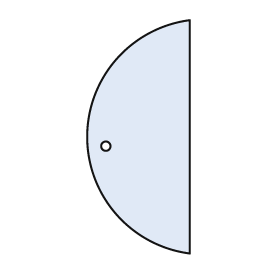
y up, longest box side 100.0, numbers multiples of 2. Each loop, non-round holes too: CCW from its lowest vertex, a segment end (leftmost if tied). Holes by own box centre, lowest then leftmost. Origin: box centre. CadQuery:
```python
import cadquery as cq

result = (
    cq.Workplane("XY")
    .moveTo(22.0, -50.0)
    .lineTo(22.0, 50.0)
    .threePointArc((-22.0, 0.0), (22.0, -50.0))
    .close()
    .moveTo(-14.0, -4.0)
    .circle(2.0)
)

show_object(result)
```